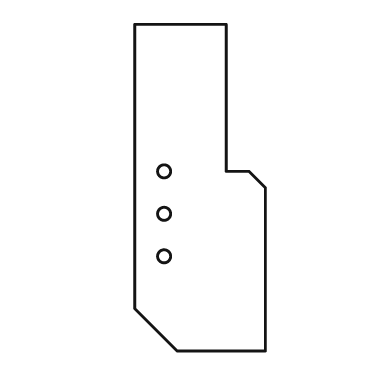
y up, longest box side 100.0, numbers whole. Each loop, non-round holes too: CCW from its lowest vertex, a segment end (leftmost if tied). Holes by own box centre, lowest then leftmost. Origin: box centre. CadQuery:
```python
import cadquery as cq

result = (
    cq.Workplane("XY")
    .moveTo(-7.0, -50.0)
    .lineTo(20.0, -50.0)
    .lineTo(20.0, 0.0)
    .lineTo(15.0, 5.0)
    .lineTo(8.0, 5.0)
    .lineTo(8.0, 50.0)
    .lineTo(-20.0, 50.0)
    .lineTo(-20.0, -37.0)
    .close()
    .moveTo(-11.0, -21.0)
    .circle(2.0)
    .moveTo(-11.0, -8.0)
    .circle(2.0)
    .moveTo(-11.0, 5.0)
    .circle(2.0)
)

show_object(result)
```